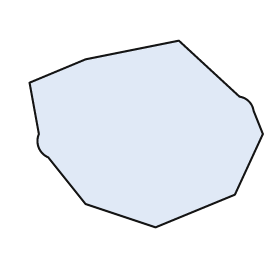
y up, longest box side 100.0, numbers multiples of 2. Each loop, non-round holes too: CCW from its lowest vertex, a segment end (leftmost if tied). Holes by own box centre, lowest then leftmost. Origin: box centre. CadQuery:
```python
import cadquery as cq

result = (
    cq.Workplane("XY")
    .moveTo(4.0, -40.0)
    .lineTo(38.0, -26.0)
    .lineTo(50.0, 0.0)
    .lineTo(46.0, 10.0)
    .threePointArc((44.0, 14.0), (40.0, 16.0))
    .lineTo(14.0, 40.0)
    .lineTo(-26.0, 32.0)
    .lineTo(-50.0, 22.0)
    .lineTo(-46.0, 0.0)
    .threePointArc((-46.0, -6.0), (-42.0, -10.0))
    .lineTo(-26.0, -30.0)
    .close()
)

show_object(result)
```